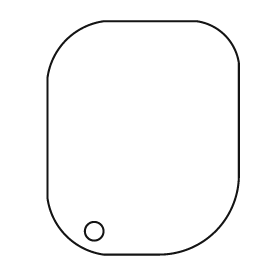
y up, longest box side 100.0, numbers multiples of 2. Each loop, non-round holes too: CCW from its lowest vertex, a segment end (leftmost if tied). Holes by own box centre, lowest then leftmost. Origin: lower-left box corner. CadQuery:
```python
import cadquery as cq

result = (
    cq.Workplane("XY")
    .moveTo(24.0, 0.0)
    .lineTo(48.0, 0.0)
    .threePointArc((72.0, 10.0), (82.0, 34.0))
    .lineTo(82.0, 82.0)
    .threePointArc((76.0, 94.0), (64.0, 100.0))
    .lineTo(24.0, 100.0)
    .threePointArc((8.0, 92.0), (0.0, 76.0))
    .lineTo(0.0, 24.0)
    .threePointArc((8.0, 8.0), (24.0, 0.0))
    .close()
    .moveTo(20.0, 10.0)
    .circle(4.0)
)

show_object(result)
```